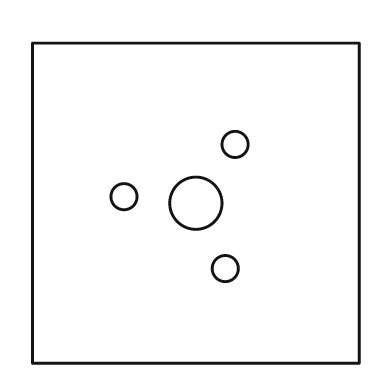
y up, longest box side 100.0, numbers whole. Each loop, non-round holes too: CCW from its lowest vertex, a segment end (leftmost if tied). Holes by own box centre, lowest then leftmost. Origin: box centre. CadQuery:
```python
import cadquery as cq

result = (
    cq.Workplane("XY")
    .moveTo(-50.0, -49.0)
    .lineTo(50.0, -49.0)
    .lineTo(50.0, 49.0)
    .lineTo(-50.0, 49.0)
    .close()
    .moveTo(9.0, -20.0)
    .circle(4.0)
    .moveTo(0.0, 0.0)
    .circle(8.0)
    .moveTo(-22.0, 2.0)
    .circle(4.0)
    .moveTo(12.0, 18.0)
    .circle(4.0)
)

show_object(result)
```